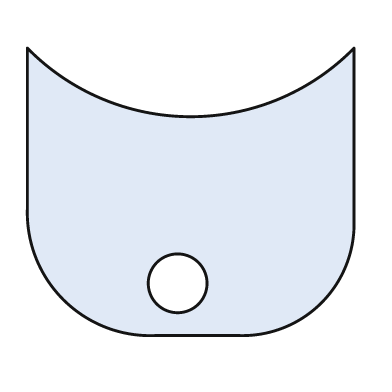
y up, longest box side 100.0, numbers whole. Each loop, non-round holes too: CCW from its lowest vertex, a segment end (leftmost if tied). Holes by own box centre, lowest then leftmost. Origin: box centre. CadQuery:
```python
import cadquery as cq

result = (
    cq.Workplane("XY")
    .moveTo(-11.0, -44.0)
    .lineTo(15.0, -44.0)
    .threePointArc((40.0, -34.0), (50.0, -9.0))
    .lineTo(50.0, 44.0)
    .threePointArc((0.0, 23.0), (-50.0, 44.0))
    .lineTo(-50.0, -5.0)
    .threePointArc((-39.0, -33.0), (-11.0, -44.0))
    .close()
    .moveTo(-4.0, -28.0)
    .circle(9.0)
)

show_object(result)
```